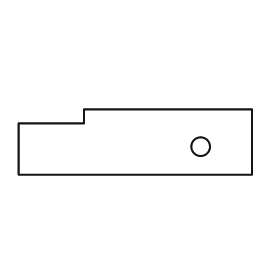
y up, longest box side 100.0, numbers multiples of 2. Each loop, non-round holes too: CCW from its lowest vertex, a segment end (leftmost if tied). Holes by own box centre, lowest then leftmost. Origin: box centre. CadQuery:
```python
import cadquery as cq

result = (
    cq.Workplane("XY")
    .moveTo(-50.0, -14.0)
    .lineTo(50.0, -14.0)
    .lineTo(50.0, 14.0)
    .lineTo(-22.0, 14.0)
    .lineTo(-22.0, 8.0)
    .lineTo(-50.0, 8.0)
    .close()
    .moveTo(28.0, -2.0)
    .circle(4.0)
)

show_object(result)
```